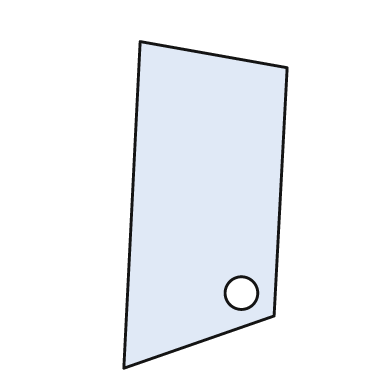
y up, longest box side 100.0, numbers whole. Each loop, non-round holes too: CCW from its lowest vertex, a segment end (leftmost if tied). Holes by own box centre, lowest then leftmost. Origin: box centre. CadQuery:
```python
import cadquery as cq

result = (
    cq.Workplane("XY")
    .moveTo(-25.0, -50.0)
    .lineTo(21.0, -34.0)
    .lineTo(25.0, 42.0)
    .lineTo(-20.0, 50.0)
    .close()
    .moveTo(11.0, -27.0)
    .circle(5.0)
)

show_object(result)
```